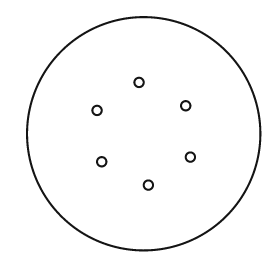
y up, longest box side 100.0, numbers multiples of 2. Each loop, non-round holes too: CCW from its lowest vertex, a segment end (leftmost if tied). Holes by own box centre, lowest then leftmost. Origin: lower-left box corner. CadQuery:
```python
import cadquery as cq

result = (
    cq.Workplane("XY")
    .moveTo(50.0, 50.0)
    .circle(50.0)
    .moveTo(52.0, 28.0)
    .circle(2.0)
    .moveTo(32.0, 38.0)
    .circle(2.0)
    .moveTo(70.0, 40.0)
    .circle(2.0)
    .moveTo(30.0, 60.0)
    .circle(2.0)
    .moveTo(68.0, 62.0)
    .circle(2.0)
    .moveTo(48.0, 72.0)
    .circle(2.0)
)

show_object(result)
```